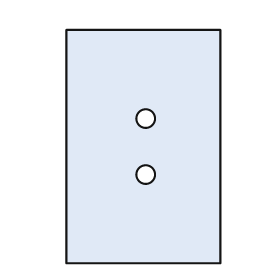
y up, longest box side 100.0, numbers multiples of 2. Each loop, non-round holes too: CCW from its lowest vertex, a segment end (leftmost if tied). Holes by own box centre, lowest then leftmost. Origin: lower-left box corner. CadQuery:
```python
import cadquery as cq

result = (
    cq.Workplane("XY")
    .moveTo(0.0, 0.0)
    .lineTo(66.0, 0.0)
    .lineTo(66.0, 100.0)
    .lineTo(0.0, 100.0)
    .close()
    .moveTo(34.0, 38.0)
    .circle(4.0)
    .moveTo(34.0, 62.0)
    .circle(4.0)
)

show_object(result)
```